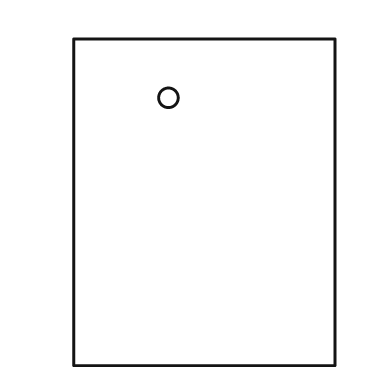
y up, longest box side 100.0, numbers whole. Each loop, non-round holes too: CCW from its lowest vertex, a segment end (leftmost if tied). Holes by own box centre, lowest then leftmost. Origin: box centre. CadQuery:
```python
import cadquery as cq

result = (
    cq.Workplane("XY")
    .moveTo(-40.0, -50.0)
    .lineTo(40.0, -50.0)
    .lineTo(40.0, 50.0)
    .lineTo(-40.0, 50.0)
    .close()
    .moveTo(-11.0, 32.0)
    .circle(3.0)
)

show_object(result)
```